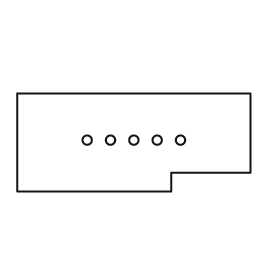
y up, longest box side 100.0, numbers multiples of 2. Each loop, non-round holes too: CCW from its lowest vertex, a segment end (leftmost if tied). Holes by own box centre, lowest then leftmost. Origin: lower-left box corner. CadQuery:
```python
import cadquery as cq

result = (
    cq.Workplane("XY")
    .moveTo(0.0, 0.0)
    .lineTo(66.0, 0.0)
    .lineTo(66.0, 8.0)
    .lineTo(100.0, 8.0)
    .lineTo(100.0, 42.0)
    .lineTo(0.0, 42.0)
    .close()
    .moveTo(30.0, 22.0)
    .circle(2.0)
    .moveTo(40.0, 22.0)
    .circle(2.0)
    .moveTo(50.0, 22.0)
    .circle(2.0)
    .moveTo(60.0, 22.0)
    .circle(2.0)
    .moveTo(70.0, 22.0)
    .circle(2.0)
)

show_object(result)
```